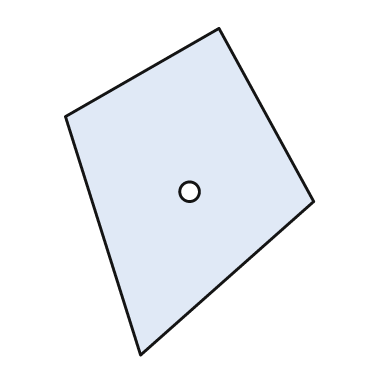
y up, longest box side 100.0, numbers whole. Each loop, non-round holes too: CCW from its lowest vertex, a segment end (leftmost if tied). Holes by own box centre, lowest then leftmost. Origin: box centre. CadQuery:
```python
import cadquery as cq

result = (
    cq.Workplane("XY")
    .moveTo(-15.0, -50.0)
    .lineTo(38.0, -3.0)
    .lineTo(9.0, 50.0)
    .lineTo(-38.0, 23.0)
    .close()
    .moveTo(0.0, 0.0)
    .circle(3.0)
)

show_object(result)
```